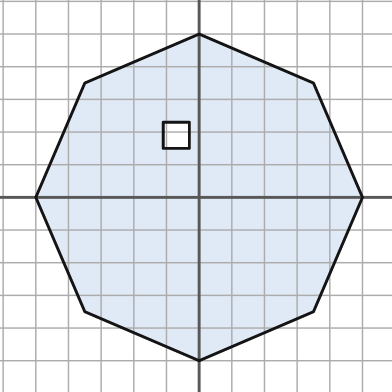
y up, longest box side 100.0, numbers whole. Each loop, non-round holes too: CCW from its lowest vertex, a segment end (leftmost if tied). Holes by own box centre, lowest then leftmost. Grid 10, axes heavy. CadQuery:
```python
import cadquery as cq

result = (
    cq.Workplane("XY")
    .moveTo(0.0, -50.0)
    .lineTo(35.0, -35.0)
    .lineTo(50.0, 0.0)
    .lineTo(35.0, 35.0)
    .lineTo(0.0, 50.0)
    .lineTo(-35.0, 35.0)
    .lineTo(-50.0, 0.0)
    .lineTo(-35.0, -35.0)
    .close()
    .moveTo(-11.0, 15.0)
    .lineTo(-3.0, 15.0)
    .lineTo(-3.0, 23.0)
    .lineTo(-11.0, 23.0)
    .close()
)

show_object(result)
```